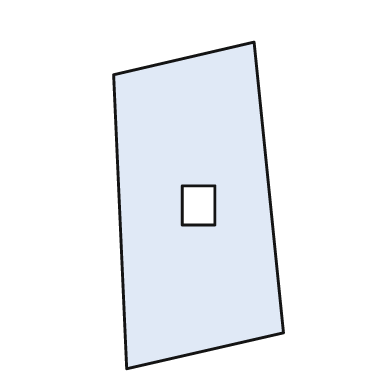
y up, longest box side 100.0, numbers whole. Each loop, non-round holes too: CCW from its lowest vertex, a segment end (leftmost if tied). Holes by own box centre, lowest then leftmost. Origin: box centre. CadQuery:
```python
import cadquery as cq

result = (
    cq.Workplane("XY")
    .moveTo(-22.0, -50.0)
    .lineTo(26.0, -39.0)
    .lineTo(17.0, 50.0)
    .lineTo(-26.0, 40.0)
    .close()
    .moveTo(-5.0, -6.0)
    .lineTo(5.0, -6.0)
    .lineTo(5.0, 6.0)
    .lineTo(-5.0, 6.0)
    .close()
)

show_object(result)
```